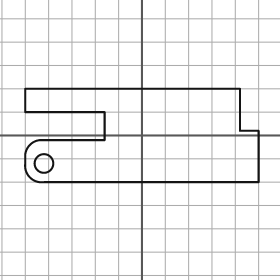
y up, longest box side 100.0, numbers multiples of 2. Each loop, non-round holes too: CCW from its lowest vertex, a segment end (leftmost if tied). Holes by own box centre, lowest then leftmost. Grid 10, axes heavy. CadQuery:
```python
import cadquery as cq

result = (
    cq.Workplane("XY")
    .moveTo(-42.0, -20.0)
    .lineTo(50.0, -20.0)
    .lineTo(50.0, 2.0)
    .lineTo(42.0, 2.0)
    .lineTo(42.0, 20.0)
    .lineTo(-50.0, 20.0)
    .lineTo(-50.0, 10.0)
    .lineTo(-16.0, 10.0)
    .lineTo(-16.0, -2.0)
    .lineTo(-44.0, -2.0)
    .threePointArc((-48.0, -4.0), (-50.0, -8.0))
    .lineTo(-50.0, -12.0)
    .threePointArc((-48.0, -18.0), (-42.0, -20.0))
    .close()
    .moveTo(-42.0, -12.0)
    .circle(4.0)
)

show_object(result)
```